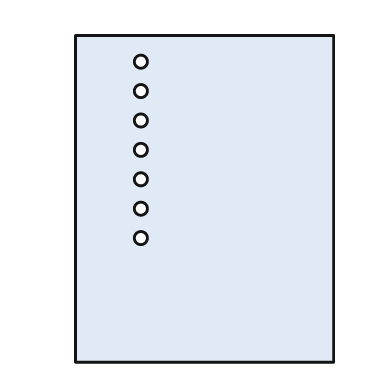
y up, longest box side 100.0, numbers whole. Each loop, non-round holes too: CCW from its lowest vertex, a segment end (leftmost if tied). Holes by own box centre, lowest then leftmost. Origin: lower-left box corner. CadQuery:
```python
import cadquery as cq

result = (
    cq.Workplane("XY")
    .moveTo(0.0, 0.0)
    .lineTo(79.0, 0.0)
    .lineTo(79.0, 100.0)
    .lineTo(0.0, 100.0)
    .close()
    .moveTo(20.0, 38.0)
    .circle(2.0)
    .moveTo(20.0, 47.0)
    .circle(2.0)
    .moveTo(20.0, 56.0)
    .circle(2.0)
    .moveTo(20.0, 65.0)
    .circle(2.0)
    .moveTo(20.0, 74.0)
    .circle(2.0)
    .moveTo(20.0, 83.0)
    .circle(2.0)
    .moveTo(20.0, 92.0)
    .circle(2.0)
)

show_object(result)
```